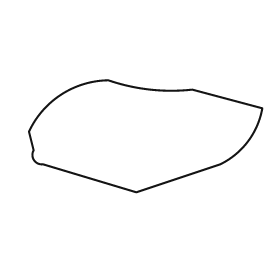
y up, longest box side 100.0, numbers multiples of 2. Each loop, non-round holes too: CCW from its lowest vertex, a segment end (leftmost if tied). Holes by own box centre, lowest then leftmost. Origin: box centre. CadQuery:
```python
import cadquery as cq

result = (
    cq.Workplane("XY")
    .moveTo(-4.0, -24.0)
    .lineTo(32.0, -12.0)
    .threePointArc((44.0, -2.0), (50.0, 12.0))
    .lineTo(20.0, 20.0)
    .threePointArc((2.0, 20.0), (-16.0, 24.0))
    .threePointArc((-36.0, 18.0), (-50.0, 2.0))
    .lineTo(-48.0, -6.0)
    .threePointArc((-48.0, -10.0), (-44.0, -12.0))
    .close()
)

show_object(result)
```